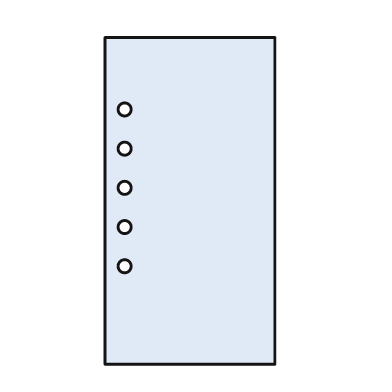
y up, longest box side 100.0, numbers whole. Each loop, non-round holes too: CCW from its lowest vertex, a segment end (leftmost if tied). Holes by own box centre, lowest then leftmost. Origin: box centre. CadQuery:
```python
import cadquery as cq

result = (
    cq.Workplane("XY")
    .moveTo(-26.0, -50.0)
    .lineTo(26.0, -50.0)
    .lineTo(26.0, 50.0)
    .lineTo(-26.0, 50.0)
    .close()
    .moveTo(-20.0, -20.0)
    .circle(2.0)
    .moveTo(-20.0, -8.0)
    .circle(2.0)
    .moveTo(-20.0, 4.0)
    .circle(2.0)
    .moveTo(-20.0, 16.0)
    .circle(2.0)
    .moveTo(-20.0, 28.0)
    .circle(2.0)
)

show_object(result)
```